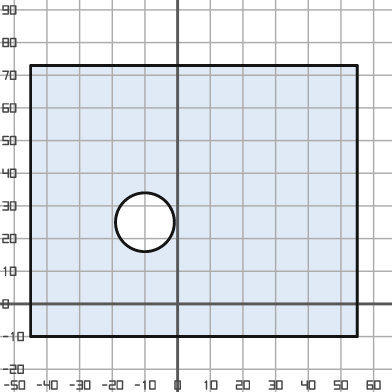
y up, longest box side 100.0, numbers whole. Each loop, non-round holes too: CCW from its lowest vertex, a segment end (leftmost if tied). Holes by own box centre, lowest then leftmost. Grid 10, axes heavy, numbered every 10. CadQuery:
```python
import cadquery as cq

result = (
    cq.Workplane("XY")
    .moveTo(-45.0, -10.0)
    .lineTo(55.0, -10.0)
    .lineTo(55.0, 73.0)
    .lineTo(-45.0, 73.0)
    .close()
    .moveTo(-10.0, 25.0)
    .circle(9.0)
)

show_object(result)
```